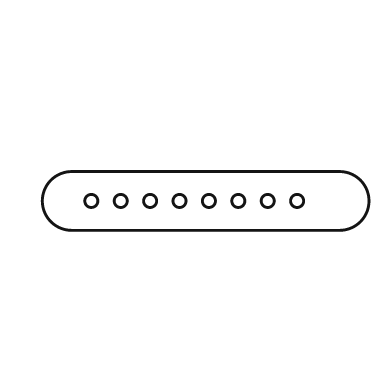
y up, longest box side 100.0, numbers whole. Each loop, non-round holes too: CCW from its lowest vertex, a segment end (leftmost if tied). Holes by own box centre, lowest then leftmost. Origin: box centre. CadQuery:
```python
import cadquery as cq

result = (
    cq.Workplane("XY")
    .moveTo(-41.0, -9.0)
    .lineTo(41.0, -9.0)
    .threePointArc((50.0, 0.0), (41.0, 9.0))
    .lineTo(-41.0, 9.0)
    .threePointArc((-50.0, 0.0), (-41.0, -9.0))
    .close()
    .moveTo(-35.0, 0.0)
    .circle(2.0)
    .moveTo(-26.0, 0.0)
    .circle(2.0)
    .moveTo(-17.0, 0.0)
    .circle(2.0)
    .moveTo(-8.0, 0.0)
    .circle(2.0)
    .moveTo(1.0, 0.0)
    .circle(2.0)
    .moveTo(10.0, 0.0)
    .circle(2.0)
    .moveTo(19.0, 0.0)
    .circle(2.0)
    .moveTo(28.0, 0.0)
    .circle(2.0)
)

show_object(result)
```